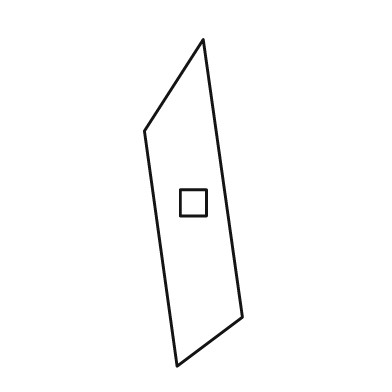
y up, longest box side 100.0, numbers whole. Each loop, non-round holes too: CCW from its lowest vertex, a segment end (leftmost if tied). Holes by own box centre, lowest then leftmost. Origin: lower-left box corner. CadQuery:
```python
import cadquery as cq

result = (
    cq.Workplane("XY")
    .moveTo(10.0, 0.0)
    .lineTo(30.0, 15.0)
    .lineTo(18.0, 100.0)
    .lineTo(0.0, 72.0)
    .close()
    .moveTo(11.0, 46.0)
    .lineTo(19.0, 46.0)
    .lineTo(19.0, 54.0)
    .lineTo(11.0, 54.0)
    .close()
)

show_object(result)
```